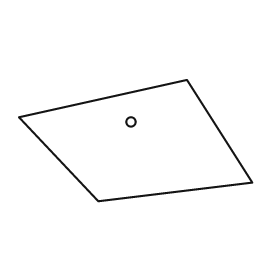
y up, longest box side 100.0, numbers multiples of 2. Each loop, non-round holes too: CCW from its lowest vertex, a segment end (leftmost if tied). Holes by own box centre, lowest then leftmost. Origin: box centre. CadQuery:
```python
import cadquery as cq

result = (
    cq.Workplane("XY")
    .moveTo(-16.0, -26.0)
    .lineTo(50.0, -18.0)
    .lineTo(22.0, 26.0)
    .lineTo(-50.0, 10.0)
    .close()
    .moveTo(-2.0, 8.0)
    .circle(2.0)
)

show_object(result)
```